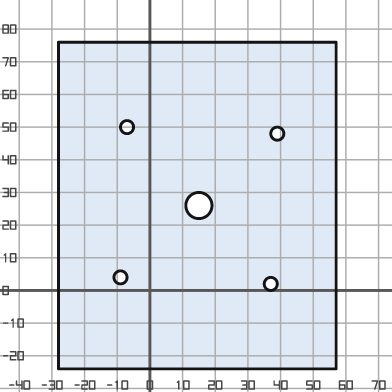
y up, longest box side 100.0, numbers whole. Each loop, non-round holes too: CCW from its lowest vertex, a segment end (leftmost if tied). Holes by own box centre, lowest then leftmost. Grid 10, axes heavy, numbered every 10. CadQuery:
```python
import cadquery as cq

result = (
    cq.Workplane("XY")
    .moveTo(-28.0, -24.0)
    .lineTo(57.0, -24.0)
    .lineTo(57.0, 76.0)
    .lineTo(-28.0, 76.0)
    .close()
    .moveTo(37.0, 2.0)
    .circle(2.0)
    .moveTo(-9.0, 4.0)
    .circle(2.0)
    .moveTo(15.0, 26.0)
    .circle(4.0)
    .moveTo(39.0, 48.0)
    .circle(2.0)
    .moveTo(-7.0, 50.0)
    .circle(2.0)
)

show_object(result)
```